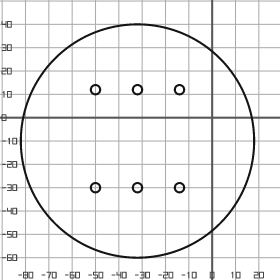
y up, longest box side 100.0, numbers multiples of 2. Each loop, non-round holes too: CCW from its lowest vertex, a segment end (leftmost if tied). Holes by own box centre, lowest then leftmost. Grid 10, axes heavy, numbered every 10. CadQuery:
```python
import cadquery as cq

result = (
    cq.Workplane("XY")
    .moveTo(-32.0, -10.0)
    .circle(50.0)
    .moveTo(-50.0, -30.0)
    .circle(2.0)
    .moveTo(-32.0, -30.0)
    .circle(2.0)
    .moveTo(-14.0, -30.0)
    .circle(2.0)
    .moveTo(-50.0, 12.0)
    .circle(2.0)
    .moveTo(-32.0, 12.0)
    .circle(2.0)
    .moveTo(-14.0, 12.0)
    .circle(2.0)
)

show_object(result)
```